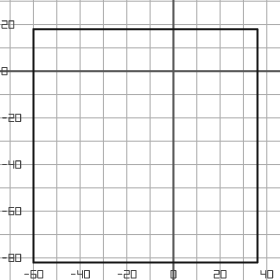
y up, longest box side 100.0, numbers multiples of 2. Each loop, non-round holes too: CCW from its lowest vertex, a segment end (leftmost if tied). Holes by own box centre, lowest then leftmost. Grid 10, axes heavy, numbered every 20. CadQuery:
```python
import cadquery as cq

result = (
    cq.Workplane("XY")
    .moveTo(-60.0, -82.0)
    .lineTo(36.0, -82.0)
    .lineTo(36.0, 18.0)
    .lineTo(-60.0, 18.0)
    .close()
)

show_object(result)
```